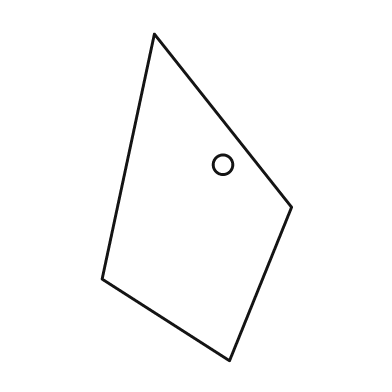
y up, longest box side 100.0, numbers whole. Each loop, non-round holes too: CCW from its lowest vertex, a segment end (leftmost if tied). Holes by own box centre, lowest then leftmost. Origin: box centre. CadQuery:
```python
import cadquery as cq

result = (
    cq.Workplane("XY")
    .moveTo(10.0, -50.0)
    .lineTo(29.0, -3.0)
    .lineTo(-13.0, 50.0)
    .lineTo(-29.0, -25.0)
    .close()
    .moveTo(8.0, 10.0)
    .circle(3.0)
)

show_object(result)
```